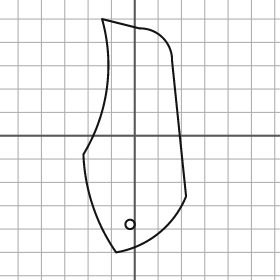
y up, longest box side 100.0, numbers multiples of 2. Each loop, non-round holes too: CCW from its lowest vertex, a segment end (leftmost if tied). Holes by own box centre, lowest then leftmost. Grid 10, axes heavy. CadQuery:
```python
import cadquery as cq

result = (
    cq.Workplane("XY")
    .moveTo(-8.0, -50.0)
    .threePointArc((10.0, -42.0), (22.0, -26.0))
    .lineTo(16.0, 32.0)
    .threePointArc((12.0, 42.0), (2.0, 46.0))
    .lineTo(-14.0, 50.0)
    .threePointArc((-12.0, 20.0), (-22.0, -8.0))
    .threePointArc((-18.0, -30.0), (-8.0, -50.0))
    .close()
    .moveTo(-2.0, -38.0)
    .circle(2.0)
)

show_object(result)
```